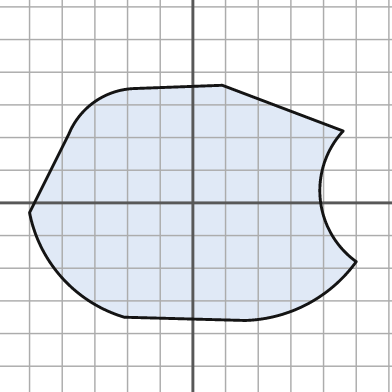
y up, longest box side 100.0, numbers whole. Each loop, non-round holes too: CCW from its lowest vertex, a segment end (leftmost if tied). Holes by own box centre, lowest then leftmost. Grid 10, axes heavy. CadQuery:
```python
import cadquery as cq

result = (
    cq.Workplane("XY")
    .moveTo(16.0, -36.0)
    .threePointArc((35.0, -31.0), (50.0, -18.0))
    .threePointArc((39.0, 1.0), (46.0, 22.0))
    .lineTo(9.0, 36.0)
    .lineTo(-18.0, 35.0)
    .threePointArc((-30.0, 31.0), (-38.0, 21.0))
    .lineTo(-50.0, -3.0)
    .threePointArc((-40.0, -23.0), (-21.0, -35.0))
    .close()
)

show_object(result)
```